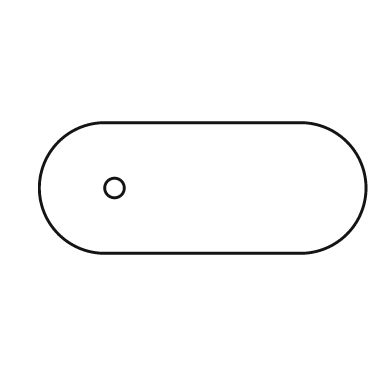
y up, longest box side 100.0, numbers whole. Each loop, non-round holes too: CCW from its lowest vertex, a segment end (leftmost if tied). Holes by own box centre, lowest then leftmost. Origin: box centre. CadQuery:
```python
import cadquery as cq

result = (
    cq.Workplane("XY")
    .moveTo(-30.0, -20.0)
    .lineTo(30.0, -20.0)
    .threePointArc((50.0, 0.0), (30.0, 20.0))
    .lineTo(-30.0, 20.0)
    .threePointArc((-50.0, 0.0), (-30.0, -20.0))
    .close()
    .moveTo(-27.0, 0.0)
    .circle(3.0)
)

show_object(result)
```